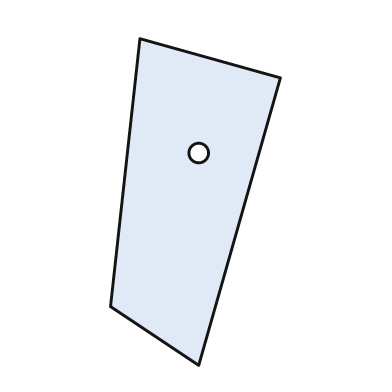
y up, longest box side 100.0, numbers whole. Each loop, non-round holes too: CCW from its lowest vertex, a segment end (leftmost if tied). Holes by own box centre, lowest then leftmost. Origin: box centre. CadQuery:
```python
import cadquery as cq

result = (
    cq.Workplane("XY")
    .moveTo(1.0, -50.0)
    .lineTo(26.0, 38.0)
    .lineTo(-17.0, 50.0)
    .lineTo(-26.0, -32.0)
    .close()
    .moveTo(1.0, 15.0)
    .circle(3.0)
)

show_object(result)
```